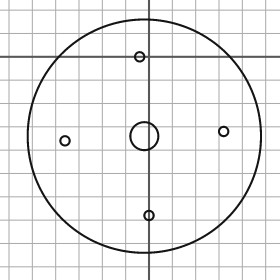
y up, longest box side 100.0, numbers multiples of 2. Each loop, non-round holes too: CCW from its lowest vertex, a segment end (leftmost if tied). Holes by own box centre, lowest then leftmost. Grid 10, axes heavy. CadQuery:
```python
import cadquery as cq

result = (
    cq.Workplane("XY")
    .moveTo(-2.0, -34.0)
    .circle(50.0)
    .moveTo(0.0, -68.0)
    .circle(2.0)
    .moveTo(-36.0, -36.0)
    .circle(2.0)
    .moveTo(-2.0, -34.0)
    .circle(6.0)
    .moveTo(32.0, -32.0)
    .circle(2.0)
    .moveTo(-4.0, 0.0)
    .circle(2.0)
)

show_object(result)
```